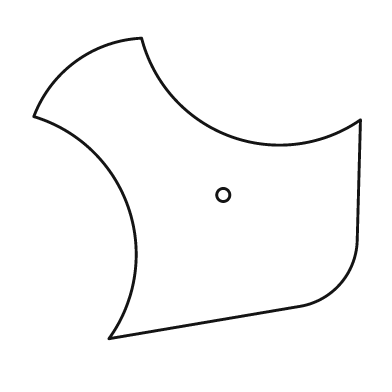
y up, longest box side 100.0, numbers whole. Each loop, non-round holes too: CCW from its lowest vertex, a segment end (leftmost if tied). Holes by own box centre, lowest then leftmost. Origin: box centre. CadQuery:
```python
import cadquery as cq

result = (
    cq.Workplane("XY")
    .moveTo(-27.0, -46.0)
    .lineTo(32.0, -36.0)
    .threePointArc((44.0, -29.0), (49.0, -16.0))
    .lineTo(50.0, 21.0)
    .threePointArc((10.0, 16.0), (-17.0, 46.0))
    .threePointArc((-37.0, 39.0), (-50.0, 22.0))
    .threePointArc((-21.0, -6.0), (-27.0, -46.0))
    .close()
    .moveTo(8.0, -2.0)
    .circle(2.0)
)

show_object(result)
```